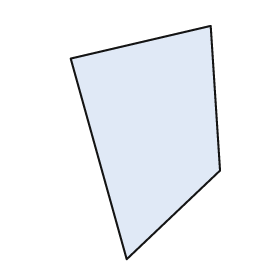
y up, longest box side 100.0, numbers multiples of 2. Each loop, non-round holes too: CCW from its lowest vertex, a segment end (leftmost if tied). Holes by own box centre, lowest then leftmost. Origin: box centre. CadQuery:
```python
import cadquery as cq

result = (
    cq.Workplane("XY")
    .moveTo(-8.0, -50.0)
    .lineTo(32.0, -12.0)
    .lineTo(28.0, 50.0)
    .lineTo(-32.0, 36.0)
    .close()
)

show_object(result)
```